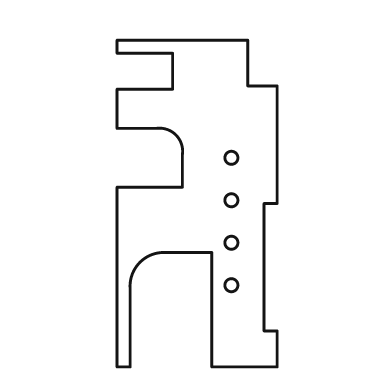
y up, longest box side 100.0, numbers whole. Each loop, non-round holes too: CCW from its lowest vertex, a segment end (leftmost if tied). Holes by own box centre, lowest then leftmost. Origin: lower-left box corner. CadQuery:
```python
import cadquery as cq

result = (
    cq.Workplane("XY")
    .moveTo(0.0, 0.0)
    .lineTo(4.0, 0.0)
    .lineTo(4.0, 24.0)
    .threePointArc((7.0, 32.0), (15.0, 35.0))
    .lineTo(29.0, 35.0)
    .lineTo(29.0, 0.0)
    .lineTo(49.0, 0.0)
    .lineTo(49.0, 11.0)
    .lineTo(45.0, 11.0)
    .lineTo(45.0, 50.0)
    .lineTo(49.0, 50.0)
    .lineTo(49.0, 86.0)
    .lineTo(40.0, 86.0)
    .lineTo(40.0, 100.0)
    .lineTo(0.0, 100.0)
    .lineTo(0.0, 96.0)
    .lineTo(17.0, 96.0)
    .lineTo(17.0, 85.0)
    .lineTo(0.0, 85.0)
    .lineTo(0.0, 73.0)
    .lineTo(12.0, 73.0)
    .threePointArc((18.0, 71.0), (20.0, 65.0))
    .lineTo(20.0, 55.0)
    .lineTo(0.0, 55.0)
    .close()
    .moveTo(35.0, 25.0)
    .circle(2.0)
    .moveTo(35.0, 38.0)
    .circle(2.0)
    .moveTo(35.0, 51.0)
    .circle(2.0)
    .moveTo(35.0, 64.0)
    .circle(2.0)
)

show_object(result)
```